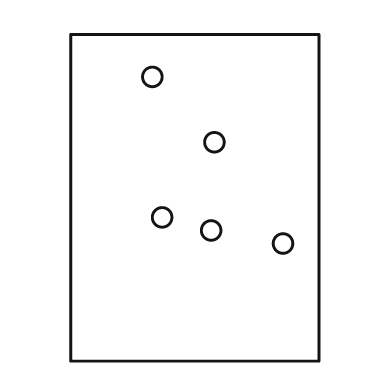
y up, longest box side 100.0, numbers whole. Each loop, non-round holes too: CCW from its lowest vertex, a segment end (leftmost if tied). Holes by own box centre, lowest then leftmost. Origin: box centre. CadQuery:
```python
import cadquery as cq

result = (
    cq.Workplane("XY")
    .moveTo(-38.0, -50.0)
    .lineTo(38.0, -50.0)
    .lineTo(38.0, 50.0)
    .lineTo(-38.0, 50.0)
    .close()
    .moveTo(27.0, -14.0)
    .circle(3.0)
    .moveTo(5.0, -10.0)
    .circle(3.0)
    .moveTo(-10.0, -6.0)
    .circle(3.0)
    .moveTo(6.0, 17.0)
    .circle(3.0)
    .moveTo(-13.0, 37.0)
    .circle(3.0)
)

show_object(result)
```